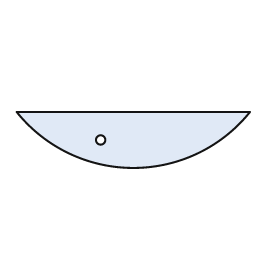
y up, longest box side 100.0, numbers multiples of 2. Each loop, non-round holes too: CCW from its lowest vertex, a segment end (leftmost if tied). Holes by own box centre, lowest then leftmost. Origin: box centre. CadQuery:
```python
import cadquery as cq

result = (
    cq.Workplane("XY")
    .moveTo(-50.0, 12.0)
    .threePointArc((0.0, -12.0), (50.0, 12.0))
    .close()
    .moveTo(-14.0, 0.0)
    .circle(2.0)
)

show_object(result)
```